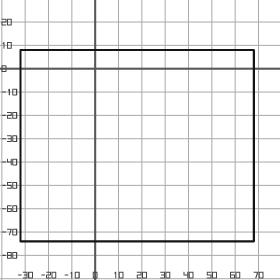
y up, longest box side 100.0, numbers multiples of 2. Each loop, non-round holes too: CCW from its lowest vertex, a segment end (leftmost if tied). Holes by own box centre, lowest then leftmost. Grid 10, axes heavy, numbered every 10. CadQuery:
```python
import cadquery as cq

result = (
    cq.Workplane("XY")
    .moveTo(-32.0, -74.0)
    .lineTo(68.0, -74.0)
    .lineTo(68.0, 8.0)
    .lineTo(-32.0, 8.0)
    .close()
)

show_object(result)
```